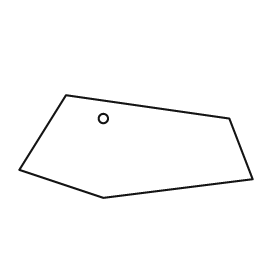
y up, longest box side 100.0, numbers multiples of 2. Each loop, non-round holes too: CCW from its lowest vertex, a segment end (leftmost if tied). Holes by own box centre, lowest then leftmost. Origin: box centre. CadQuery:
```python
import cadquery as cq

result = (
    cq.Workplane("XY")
    .moveTo(-14.0, -22.0)
    .lineTo(50.0, -14.0)
    .lineTo(40.0, 12.0)
    .lineTo(-30.0, 22.0)
    .lineTo(-50.0, -10.0)
    .close()
    .moveTo(-14.0, 12.0)
    .circle(2.0)
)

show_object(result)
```